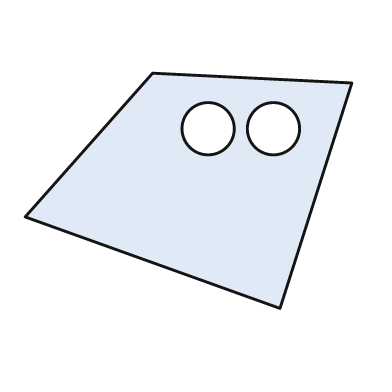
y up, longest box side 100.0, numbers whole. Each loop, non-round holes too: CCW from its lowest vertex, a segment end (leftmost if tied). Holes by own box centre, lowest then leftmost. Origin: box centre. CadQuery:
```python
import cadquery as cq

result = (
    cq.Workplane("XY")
    .moveTo(28.0, -36.0)
    .lineTo(50.0, 33.0)
    .lineTo(-11.0, 36.0)
    .lineTo(-50.0, -8.0)
    .close()
    .moveTo(6.0, 19.0)
    .circle(8.0)
    .moveTo(26.0, 19.0)
    .circle(8.0)
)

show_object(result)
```